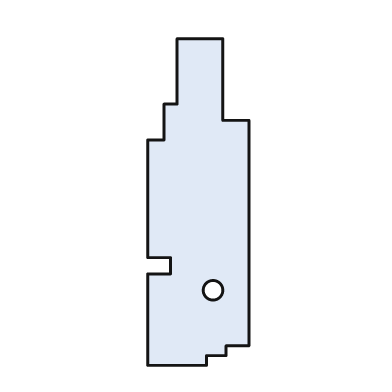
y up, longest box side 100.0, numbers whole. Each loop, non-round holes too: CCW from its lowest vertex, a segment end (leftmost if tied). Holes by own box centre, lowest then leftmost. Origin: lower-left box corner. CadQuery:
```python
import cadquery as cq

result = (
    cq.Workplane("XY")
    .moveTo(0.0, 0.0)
    .lineTo(18.0, 0.0)
    .lineTo(18.0, 3.0)
    .lineTo(24.0, 3.0)
    .lineTo(24.0, 6.0)
    .lineTo(31.0, 6.0)
    .lineTo(31.0, 75.0)
    .lineTo(23.0, 75.0)
    .lineTo(23.0, 100.0)
    .lineTo(9.0, 100.0)
    .lineTo(9.0, 80.0)
    .lineTo(5.0, 80.0)
    .lineTo(5.0, 69.0)
    .lineTo(0.0, 69.0)
    .lineTo(0.0, 33.0)
    .lineTo(7.0, 33.0)
    .lineTo(7.0, 28.0)
    .lineTo(0.0, 28.0)
    .close()
    .moveTo(20.0, 23.0)
    .circle(3.0)
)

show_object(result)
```